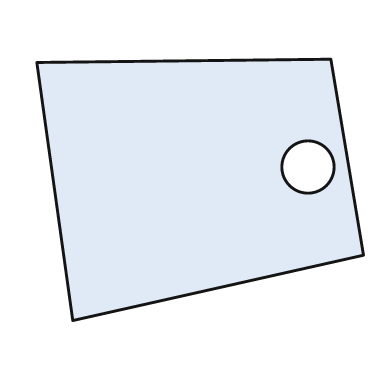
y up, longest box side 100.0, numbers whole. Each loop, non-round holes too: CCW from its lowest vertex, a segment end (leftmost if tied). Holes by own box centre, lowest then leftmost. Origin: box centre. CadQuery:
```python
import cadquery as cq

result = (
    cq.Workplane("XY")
    .moveTo(-39.0, -40.0)
    .lineTo(50.0, -20.0)
    .lineTo(40.0, 40.0)
    .lineTo(-50.0, 39.0)
    .close()
    .moveTo(33.0, 7.0)
    .circle(8.0)
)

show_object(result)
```